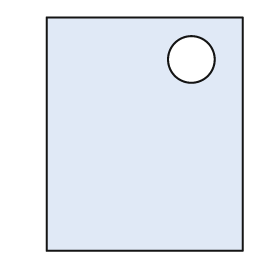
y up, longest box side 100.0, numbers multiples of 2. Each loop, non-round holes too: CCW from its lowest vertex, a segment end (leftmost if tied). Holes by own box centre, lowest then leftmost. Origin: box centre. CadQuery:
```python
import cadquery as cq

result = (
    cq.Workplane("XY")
    .moveTo(-42.0, -50.0)
    .lineTo(42.0, -50.0)
    .lineTo(42.0, 50.0)
    .lineTo(-42.0, 50.0)
    .close()
    .moveTo(20.0, 32.0)
    .circle(10.0)
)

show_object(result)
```